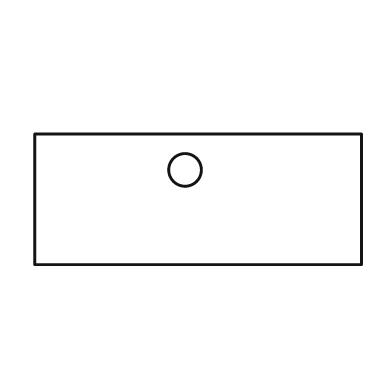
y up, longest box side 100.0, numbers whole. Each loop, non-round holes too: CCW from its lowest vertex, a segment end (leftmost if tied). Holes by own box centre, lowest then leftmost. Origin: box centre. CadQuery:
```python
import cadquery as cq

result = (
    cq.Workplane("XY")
    .moveTo(-50.0, -20.0)
    .lineTo(50.0, -20.0)
    .lineTo(50.0, 20.0)
    .lineTo(-50.0, 20.0)
    .close()
    .moveTo(-4.0, 9.0)
    .circle(5.0)
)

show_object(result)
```